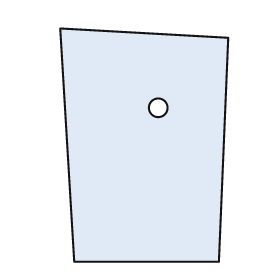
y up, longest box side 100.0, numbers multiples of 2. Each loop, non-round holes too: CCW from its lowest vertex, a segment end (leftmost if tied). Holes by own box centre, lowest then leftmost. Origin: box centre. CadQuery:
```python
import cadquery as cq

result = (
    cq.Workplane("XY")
    .moveTo(-30.0, -50.0)
    .lineTo(32.0, -50.0)
    .lineTo(36.0, 46.0)
    .lineTo(-36.0, 50.0)
    .close()
    .moveTo(6.0, 16.0)
    .circle(4.0)
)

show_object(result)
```